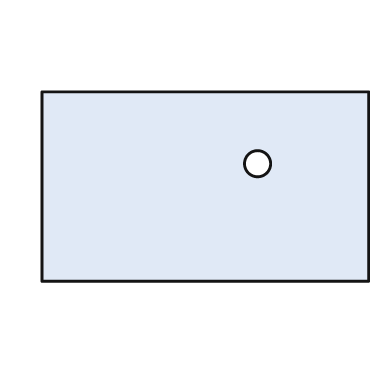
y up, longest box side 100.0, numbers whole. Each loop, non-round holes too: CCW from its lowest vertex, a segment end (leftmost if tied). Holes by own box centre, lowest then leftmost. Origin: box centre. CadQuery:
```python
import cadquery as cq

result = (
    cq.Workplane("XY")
    .moveTo(-50.0, -29.0)
    .lineTo(50.0, -29.0)
    .lineTo(50.0, 29.0)
    .lineTo(-50.0, 29.0)
    .close()
    .moveTo(16.0, 7.0)
    .circle(4.0)
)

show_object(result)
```